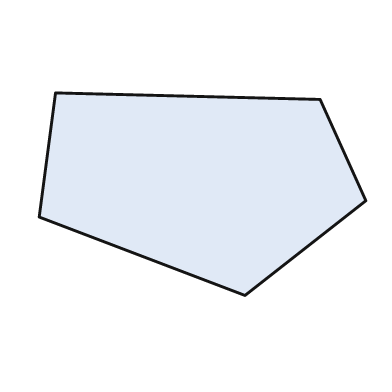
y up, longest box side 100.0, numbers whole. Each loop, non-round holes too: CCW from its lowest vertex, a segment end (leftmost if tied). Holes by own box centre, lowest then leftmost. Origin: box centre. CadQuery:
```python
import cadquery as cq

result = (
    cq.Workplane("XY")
    .moveTo(13.0, -31.0)
    .lineTo(50.0, -2.0)
    .lineTo(36.0, 29.0)
    .lineTo(-45.0, 31.0)
    .lineTo(-50.0, -7.0)
    .close()
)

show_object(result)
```